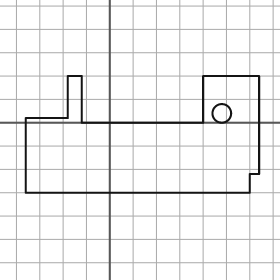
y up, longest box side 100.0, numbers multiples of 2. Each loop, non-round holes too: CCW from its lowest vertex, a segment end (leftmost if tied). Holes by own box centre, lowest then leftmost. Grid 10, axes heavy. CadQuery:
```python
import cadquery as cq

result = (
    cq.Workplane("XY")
    .moveTo(-36.0, -30.0)
    .lineTo(60.0, -30.0)
    .lineTo(60.0, -22.0)
    .lineTo(64.0, -22.0)
    .lineTo(64.0, 20.0)
    .lineTo(40.0, 20.0)
    .lineTo(40.0, 0.0)
    .lineTo(-12.0, 0.0)
    .lineTo(-12.0, 20.0)
    .lineTo(-18.0, 20.0)
    .lineTo(-18.0, 2.0)
    .lineTo(-36.0, 2.0)
    .close()
    .moveTo(48.0, 4.0)
    .circle(4.0)
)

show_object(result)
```